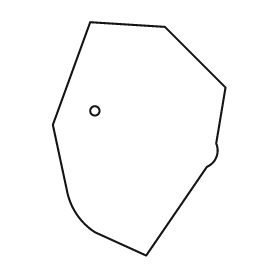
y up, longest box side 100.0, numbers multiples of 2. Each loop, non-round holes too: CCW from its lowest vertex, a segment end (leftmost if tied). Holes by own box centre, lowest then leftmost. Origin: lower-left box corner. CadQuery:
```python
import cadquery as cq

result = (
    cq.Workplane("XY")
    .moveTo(40.0, 0.0)
    .lineTo(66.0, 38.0)
    .threePointArc((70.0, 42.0), (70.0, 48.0))
    .lineTo(74.0, 72.0)
    .lineTo(48.0, 98.0)
    .lineTo(16.0, 100.0)
    .lineTo(0.0, 56.0)
    .lineTo(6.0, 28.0)
    .threePointArc((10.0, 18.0), (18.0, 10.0))
    .close()
    .moveTo(18.0, 62.0)
    .circle(2.0)
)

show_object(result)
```